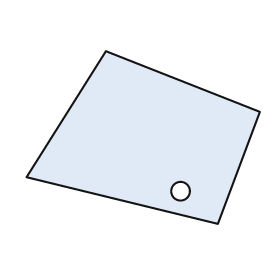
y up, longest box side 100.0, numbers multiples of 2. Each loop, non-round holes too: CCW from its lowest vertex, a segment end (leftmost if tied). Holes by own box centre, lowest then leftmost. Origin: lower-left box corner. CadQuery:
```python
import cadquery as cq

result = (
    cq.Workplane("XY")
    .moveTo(82.0, 0.0)
    .lineTo(100.0, 48.0)
    .lineTo(34.0, 74.0)
    .lineTo(0.0, 20.0)
    .close()
    .moveTo(66.0, 14.0)
    .circle(4.0)
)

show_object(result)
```